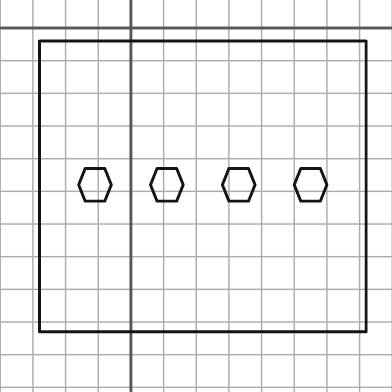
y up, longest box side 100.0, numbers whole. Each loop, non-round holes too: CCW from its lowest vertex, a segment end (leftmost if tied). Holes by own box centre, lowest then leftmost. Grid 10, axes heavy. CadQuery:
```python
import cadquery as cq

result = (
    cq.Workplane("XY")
    .moveTo(-28.0, -93.0)
    .lineTo(72.0, -93.0)
    .lineTo(72.0, -4.0)
    .lineTo(-28.0, -4.0)
    .close()
    .moveTo(-14.0, -53.0)
    .lineTo(-8.0, -53.0)
    .lineTo(-6.0, -48.0)
    .lineTo(-8.0, -43.0)
    .lineTo(-14.0, -43.0)
    .lineTo(-16.0, -48.0)
    .close()
    .moveTo(8.0, -53.0)
    .lineTo(14.0, -53.0)
    .lineTo(16.0, -48.0)
    .lineTo(14.0, -43.0)
    .lineTo(8.0, -43.0)
    .lineTo(6.0, -48.0)
    .close()
    .moveTo(30.0, -53.0)
    .lineTo(36.0, -53.0)
    .lineTo(38.0, -48.0)
    .lineTo(36.0, -43.0)
    .lineTo(30.0, -43.0)
    .lineTo(28.0, -48.0)
    .close()
    .moveTo(52.0, -53.0)
    .lineTo(58.0, -53.0)
    .lineTo(60.0, -48.0)
    .lineTo(58.0, -43.0)
    .lineTo(52.0, -43.0)
    .lineTo(50.0, -48.0)
    .close()
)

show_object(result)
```